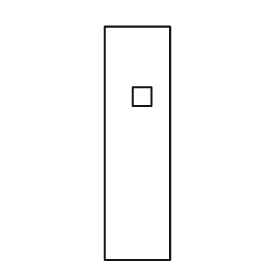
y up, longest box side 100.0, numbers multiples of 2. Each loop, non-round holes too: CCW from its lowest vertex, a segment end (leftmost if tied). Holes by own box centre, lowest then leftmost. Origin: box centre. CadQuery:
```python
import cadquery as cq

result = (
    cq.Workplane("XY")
    .moveTo(-14.0, -50.0)
    .lineTo(14.0, -50.0)
    .lineTo(14.0, 50.0)
    .lineTo(-14.0, 50.0)
    .close()
    .moveTo(-2.0, 16.0)
    .lineTo(6.0, 16.0)
    .lineTo(6.0, 24.0)
    .lineTo(-2.0, 24.0)
    .close()
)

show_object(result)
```